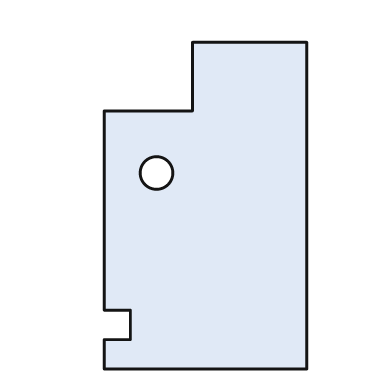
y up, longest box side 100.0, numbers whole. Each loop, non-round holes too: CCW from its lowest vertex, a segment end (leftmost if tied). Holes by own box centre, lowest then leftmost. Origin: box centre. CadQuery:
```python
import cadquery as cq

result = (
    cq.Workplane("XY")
    .moveTo(-31.0, -50.0)
    .lineTo(31.0, -50.0)
    .lineTo(31.0, 50.0)
    .lineTo(-4.0, 50.0)
    .lineTo(-4.0, 29.0)
    .lineTo(-31.0, 29.0)
    .lineTo(-31.0, -32.0)
    .lineTo(-23.0, -32.0)
    .lineTo(-23.0, -41.0)
    .lineTo(-31.0, -41.0)
    .close()
    .moveTo(-15.0, 10.0)
    .circle(5.0)
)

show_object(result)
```